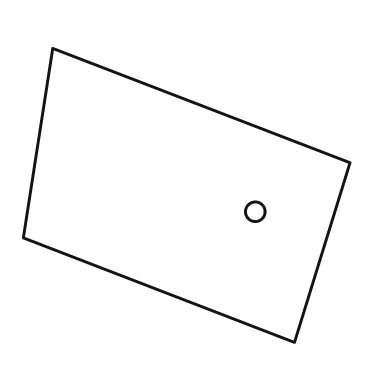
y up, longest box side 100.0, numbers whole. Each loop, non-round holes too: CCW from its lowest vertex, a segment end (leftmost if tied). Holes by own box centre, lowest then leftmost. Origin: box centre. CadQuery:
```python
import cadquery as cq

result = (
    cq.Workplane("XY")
    .moveTo(33.0, -45.0)
    .lineTo(50.0, 10.0)
    .lineTo(-41.0, 45.0)
    .lineTo(-50.0, -13.0)
    .close()
    .moveTo(21.0, -5.0)
    .circle(3.0)
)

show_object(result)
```